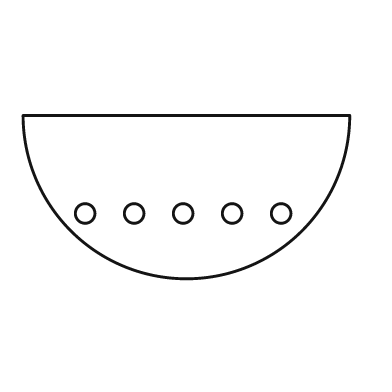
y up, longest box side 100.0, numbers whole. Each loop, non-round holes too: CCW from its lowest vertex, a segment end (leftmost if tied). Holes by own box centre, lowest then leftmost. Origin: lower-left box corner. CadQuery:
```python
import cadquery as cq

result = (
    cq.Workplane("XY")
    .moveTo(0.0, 50.0)
    .threePointArc((50.0, 0.0), (100.0, 50.0))
    .close()
    .moveTo(19.0, 20.0)
    .circle(3.0)
    .moveTo(34.0, 20.0)
    .circle(3.0)
    .moveTo(49.0, 20.0)
    .circle(3.0)
    .moveTo(64.0, 20.0)
    .circle(3.0)
    .moveTo(79.0, 20.0)
    .circle(3.0)
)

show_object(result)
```